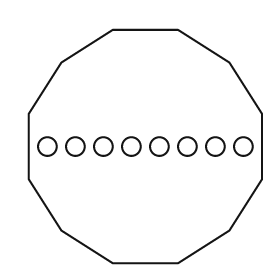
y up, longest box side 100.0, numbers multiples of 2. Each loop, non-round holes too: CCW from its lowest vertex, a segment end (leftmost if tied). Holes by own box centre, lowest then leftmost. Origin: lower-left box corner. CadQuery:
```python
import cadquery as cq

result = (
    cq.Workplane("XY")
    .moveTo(36.0, 0.0)
    .lineTo(64.0, 0.0)
    .lineTo(86.0, 14.0)
    .lineTo(100.0, 36.0)
    .lineTo(100.0, 64.0)
    .lineTo(86.0, 86.0)
    .lineTo(64.0, 100.0)
    .lineTo(36.0, 100.0)
    .lineTo(14.0, 86.0)
    .lineTo(0.0, 64.0)
    .lineTo(0.0, 36.0)
    .lineTo(14.0, 14.0)
    .close()
    .moveTo(8.0, 50.0)
    .circle(4.0)
    .moveTo(20.0, 50.0)
    .circle(4.0)
    .moveTo(32.0, 50.0)
    .circle(4.0)
    .moveTo(44.0, 50.0)
    .circle(4.0)
    .moveTo(56.0, 50.0)
    .circle(4.0)
    .moveTo(68.0, 50.0)
    .circle(4.0)
    .moveTo(80.0, 50.0)
    .circle(4.0)
    .moveTo(92.0, 50.0)
    .circle(4.0)
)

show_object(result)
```